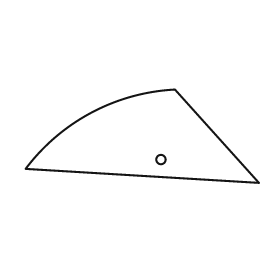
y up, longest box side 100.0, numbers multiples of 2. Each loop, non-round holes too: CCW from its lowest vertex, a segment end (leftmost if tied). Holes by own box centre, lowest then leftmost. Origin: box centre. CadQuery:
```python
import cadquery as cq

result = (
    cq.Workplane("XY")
    .moveTo(50.0, -20.0)
    .lineTo(14.0, 20.0)
    .threePointArc((-22.0, 10.0), (-50.0, -14.0))
    .close()
    .moveTo(8.0, -10.0)
    .circle(2.0)
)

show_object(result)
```